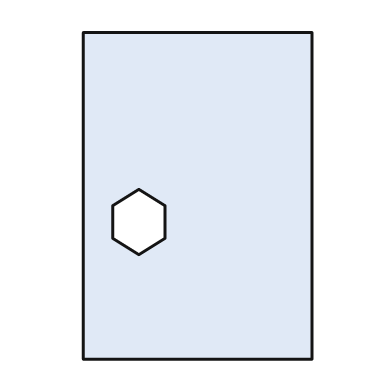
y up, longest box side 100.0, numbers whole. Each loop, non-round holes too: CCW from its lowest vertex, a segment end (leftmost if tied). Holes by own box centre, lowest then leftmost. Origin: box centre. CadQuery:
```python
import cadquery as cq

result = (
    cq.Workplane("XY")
    .moveTo(-35.0, -50.0)
    .lineTo(35.0, -50.0)
    .lineTo(35.0, 50.0)
    .lineTo(-35.0, 50.0)
    .close()
    .moveTo(-18.0, -18.0)
    .lineTo(-10.0, -13.0)
    .lineTo(-10.0, -3.0)
    .lineTo(-18.0, 2.0)
    .lineTo(-26.0, -3.0)
    .lineTo(-26.0, -13.0)
    .close()
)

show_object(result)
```